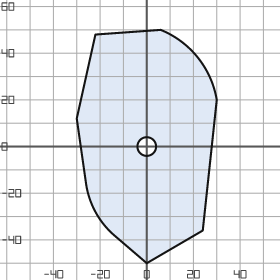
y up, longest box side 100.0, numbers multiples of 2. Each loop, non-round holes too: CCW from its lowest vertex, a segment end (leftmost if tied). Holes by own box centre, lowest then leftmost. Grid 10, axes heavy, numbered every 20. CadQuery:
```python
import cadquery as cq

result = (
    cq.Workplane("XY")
    .moveTo(0.0, -50.0)
    .lineTo(24.0, -36.0)
    .lineTo(30.0, 20.0)
    .threePointArc((22.0, 38.0), (6.0, 50.0))
    .lineTo(-22.0, 48.0)
    .lineTo(-30.0, 12.0)
    .lineTo(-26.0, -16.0)
    .threePointArc((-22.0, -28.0), (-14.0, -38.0))
    .close()
    .moveTo(0.0, 0.0)
    .circle(4.0)
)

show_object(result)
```